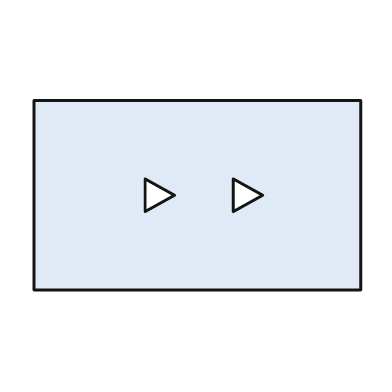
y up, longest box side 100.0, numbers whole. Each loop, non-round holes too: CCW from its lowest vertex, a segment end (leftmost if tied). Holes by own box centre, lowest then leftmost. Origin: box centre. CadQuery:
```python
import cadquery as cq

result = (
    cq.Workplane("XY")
    .moveTo(-50.0, -29.0)
    .lineTo(50.0, -29.0)
    .lineTo(50.0, 29.0)
    .lineTo(-50.0, 29.0)
    .close()
    .moveTo(-16.0, -5.0)
    .lineTo(-7.0, 0.0)
    .lineTo(-16.0, 5.0)
    .close()
    .moveTo(11.0, -5.0)
    .lineTo(20.0, 0.0)
    .lineTo(11.0, 5.0)
    .close()
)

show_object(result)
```